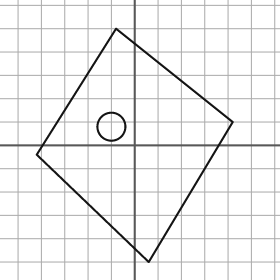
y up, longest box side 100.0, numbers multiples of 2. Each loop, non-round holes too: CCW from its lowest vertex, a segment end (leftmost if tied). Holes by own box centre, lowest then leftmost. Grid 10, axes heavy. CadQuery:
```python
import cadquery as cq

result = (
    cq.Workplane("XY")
    .moveTo(6.0, -50.0)
    .lineTo(42.0, 10.0)
    .lineTo(-8.0, 50.0)
    .lineTo(-42.0, -4.0)
    .close()
    .moveTo(-10.0, 8.0)
    .circle(6.0)
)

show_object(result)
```